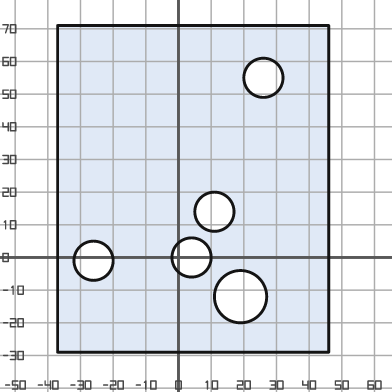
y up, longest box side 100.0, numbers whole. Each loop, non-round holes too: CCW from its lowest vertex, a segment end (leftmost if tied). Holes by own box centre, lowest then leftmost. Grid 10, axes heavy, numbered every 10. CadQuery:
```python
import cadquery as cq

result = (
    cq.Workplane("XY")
    .moveTo(-37.0, -29.0)
    .lineTo(46.0, -29.0)
    .lineTo(46.0, 71.0)
    .lineTo(-37.0, 71.0)
    .close()
    .moveTo(19.0, -12.0)
    .circle(8.0)
    .moveTo(-26.0, -1.0)
    .circle(6.0)
    .moveTo(4.0, 0.0)
    .circle(6.0)
    .moveTo(11.0, 14.0)
    .circle(6.0)
    .moveTo(26.0, 55.0)
    .circle(6.0)
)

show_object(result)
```